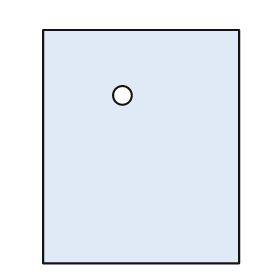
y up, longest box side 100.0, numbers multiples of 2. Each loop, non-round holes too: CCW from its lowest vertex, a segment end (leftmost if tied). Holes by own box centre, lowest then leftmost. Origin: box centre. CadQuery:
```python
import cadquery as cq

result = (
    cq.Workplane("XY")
    .moveTo(-42.0, -50.0)
    .lineTo(42.0, -50.0)
    .lineTo(42.0, 50.0)
    .lineTo(-42.0, 50.0)
    .close()
    .moveTo(-8.0, 22.0)
    .circle(4.0)
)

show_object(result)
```